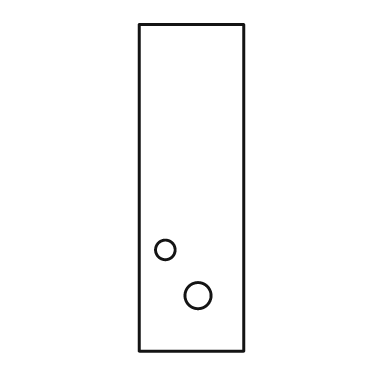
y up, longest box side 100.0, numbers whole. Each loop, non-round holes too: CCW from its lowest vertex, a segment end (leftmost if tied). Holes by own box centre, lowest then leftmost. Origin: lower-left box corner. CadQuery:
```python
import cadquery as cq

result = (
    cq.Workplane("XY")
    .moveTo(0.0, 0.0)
    .lineTo(32.0, 0.0)
    .lineTo(32.0, 100.0)
    .lineTo(0.0, 100.0)
    .close()
    .moveTo(18.0, 17.0)
    .circle(4.0)
    .moveTo(8.0, 31.0)
    .circle(3.0)
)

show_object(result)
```